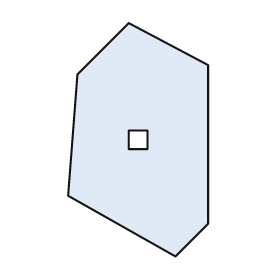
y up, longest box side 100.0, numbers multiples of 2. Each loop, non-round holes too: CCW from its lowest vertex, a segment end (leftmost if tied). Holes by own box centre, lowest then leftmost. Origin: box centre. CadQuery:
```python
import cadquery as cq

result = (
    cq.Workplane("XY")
    .moveTo(16.0, -50.0)
    .lineTo(30.0, -36.0)
    .lineTo(30.0, 32.0)
    .lineTo(-4.0, 50.0)
    .lineTo(-26.0, 28.0)
    .lineTo(-30.0, -24.0)
    .close()
    .moveTo(-4.0, -4.0)
    .lineTo(4.0, -4.0)
    .lineTo(4.0, 4.0)
    .lineTo(-4.0, 4.0)
    .close()
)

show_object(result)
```